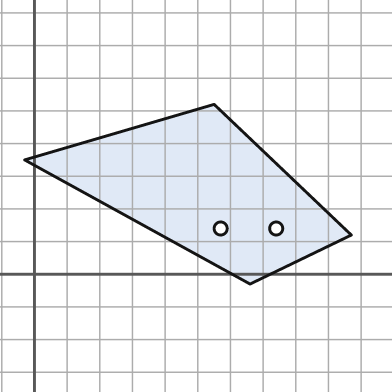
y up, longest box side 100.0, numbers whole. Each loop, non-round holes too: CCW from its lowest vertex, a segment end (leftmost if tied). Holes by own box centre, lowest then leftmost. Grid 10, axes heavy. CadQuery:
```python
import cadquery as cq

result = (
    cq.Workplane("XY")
    .moveTo(66.0, -3.0)
    .lineTo(97.0, 12.0)
    .lineTo(55.0, 52.0)
    .lineTo(-3.0, 35.0)
    .close()
    .moveTo(57.0, 14.0)
    .circle(2.0)
    .moveTo(74.0, 14.0)
    .circle(2.0)
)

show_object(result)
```